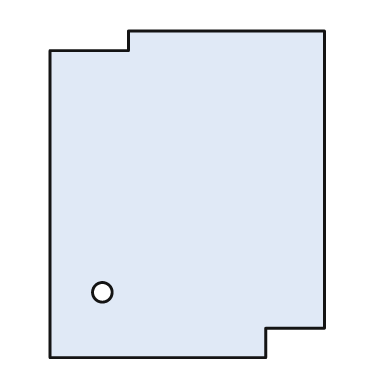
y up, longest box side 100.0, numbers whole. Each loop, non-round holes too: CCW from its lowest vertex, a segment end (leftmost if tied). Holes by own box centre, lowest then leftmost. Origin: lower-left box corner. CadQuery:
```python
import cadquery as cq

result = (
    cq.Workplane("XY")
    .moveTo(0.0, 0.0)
    .lineTo(66.0, 0.0)
    .lineTo(66.0, 9.0)
    .lineTo(84.0, 9.0)
    .lineTo(84.0, 100.0)
    .lineTo(24.0, 100.0)
    .lineTo(24.0, 94.0)
    .lineTo(0.0, 94.0)
    .close()
    .moveTo(16.0, 20.0)
    .circle(3.0)
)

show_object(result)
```